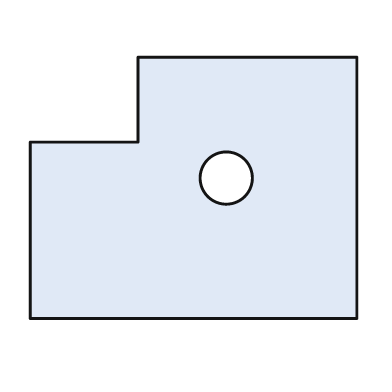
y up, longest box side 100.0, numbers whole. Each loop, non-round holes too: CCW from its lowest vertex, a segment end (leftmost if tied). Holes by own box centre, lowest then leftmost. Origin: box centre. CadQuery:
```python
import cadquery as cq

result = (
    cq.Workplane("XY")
    .moveTo(-50.0, -40.0)
    .lineTo(50.0, -40.0)
    .lineTo(50.0, 40.0)
    .lineTo(-17.0, 40.0)
    .lineTo(-17.0, 14.0)
    .lineTo(-50.0, 14.0)
    .close()
    .moveTo(10.0, 3.0)
    .circle(8.0)
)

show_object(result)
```